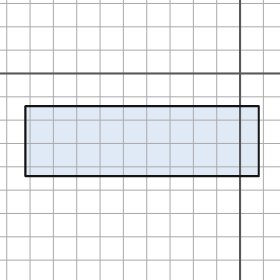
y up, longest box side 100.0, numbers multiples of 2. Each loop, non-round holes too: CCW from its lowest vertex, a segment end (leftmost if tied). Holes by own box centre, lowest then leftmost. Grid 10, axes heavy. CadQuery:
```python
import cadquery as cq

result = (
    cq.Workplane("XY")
    .moveTo(-92.0, -44.0)
    .lineTo(8.0, -44.0)
    .lineTo(8.0, -14.0)
    .lineTo(-92.0, -14.0)
    .close()
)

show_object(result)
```